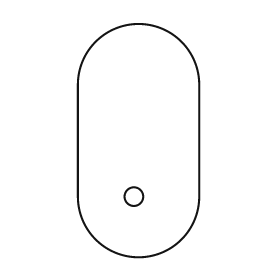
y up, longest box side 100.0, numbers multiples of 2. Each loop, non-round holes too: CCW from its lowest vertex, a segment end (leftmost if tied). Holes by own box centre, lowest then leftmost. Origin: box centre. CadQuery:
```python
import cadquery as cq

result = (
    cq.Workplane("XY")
    .moveTo(-26.0, -24.0)
    .threePointArc((0.0, -50.0), (26.0, -24.0))
    .lineTo(26.0, 24.0)
    .threePointArc((0.0, 50.0), (-26.0, 24.0))
    .close()
    .moveTo(-2.0, -24.0)
    .circle(4.0)
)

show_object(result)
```